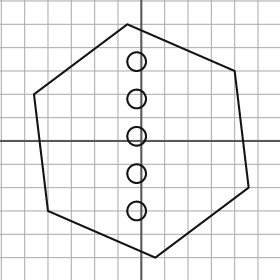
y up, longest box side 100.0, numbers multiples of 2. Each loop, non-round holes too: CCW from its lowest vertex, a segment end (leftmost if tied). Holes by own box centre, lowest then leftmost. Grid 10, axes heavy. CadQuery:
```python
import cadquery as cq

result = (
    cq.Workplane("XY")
    .moveTo(6.0, -50.0)
    .lineTo(46.0, -20.0)
    .lineTo(40.0, 30.0)
    .lineTo(-6.0, 50.0)
    .lineTo(-46.0, 20.0)
    .lineTo(-40.0, -30.0)
    .close()
    .moveTo(-2.0, -30.0)
    .circle(4.0)
    .moveTo(-2.0, -14.0)
    .circle(4.0)
    .moveTo(-2.0, 2.0)
    .circle(4.0)
    .moveTo(-2.0, 18.0)
    .circle(4.0)
    .moveTo(-2.0, 34.0)
    .circle(4.0)
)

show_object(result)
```